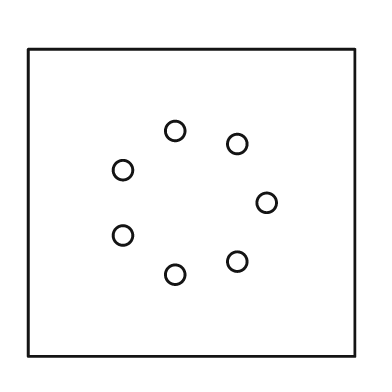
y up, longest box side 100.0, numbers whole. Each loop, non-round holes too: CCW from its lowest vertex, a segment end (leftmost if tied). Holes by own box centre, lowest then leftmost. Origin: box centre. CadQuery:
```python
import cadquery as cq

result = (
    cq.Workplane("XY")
    .moveTo(-50.0, -47.0)
    .lineTo(50.0, -47.0)
    .lineTo(50.0, 47.0)
    .lineTo(-50.0, 47.0)
    .close()
    .moveTo(-5.0, -22.0)
    .circle(3.0)
    .moveTo(14.0, -18.0)
    .circle(3.0)
    .moveTo(-21.0, -10.0)
    .circle(3.0)
    .moveTo(23.0, 0.0)
    .circle(3.0)
    .moveTo(-21.0, 10.0)
    .circle(3.0)
    .moveTo(14.0, 18.0)
    .circle(3.0)
    .moveTo(-5.0, 22.0)
    .circle(3.0)
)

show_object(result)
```